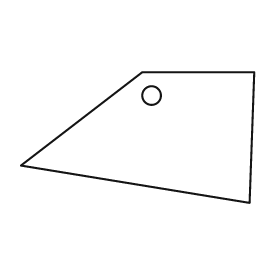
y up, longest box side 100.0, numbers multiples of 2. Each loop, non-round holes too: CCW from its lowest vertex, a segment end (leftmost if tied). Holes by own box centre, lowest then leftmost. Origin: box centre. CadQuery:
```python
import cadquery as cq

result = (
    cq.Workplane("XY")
    .moveTo(48.0, -28.0)
    .lineTo(50.0, 28.0)
    .lineTo(2.0, 28.0)
    .lineTo(-50.0, -12.0)
    .close()
    .moveTo(6.0, 18.0)
    .circle(4.0)
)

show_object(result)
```